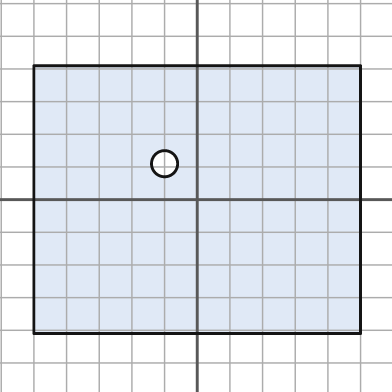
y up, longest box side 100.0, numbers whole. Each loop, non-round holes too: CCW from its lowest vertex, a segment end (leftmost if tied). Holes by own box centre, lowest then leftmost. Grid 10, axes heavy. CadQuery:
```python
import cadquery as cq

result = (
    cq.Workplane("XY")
    .moveTo(-50.0, -41.0)
    .lineTo(50.0, -41.0)
    .lineTo(50.0, 41.0)
    .lineTo(-50.0, 41.0)
    .close()
    .moveTo(-10.0, 11.0)
    .circle(4.0)
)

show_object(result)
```